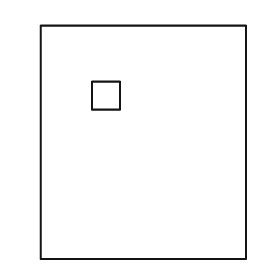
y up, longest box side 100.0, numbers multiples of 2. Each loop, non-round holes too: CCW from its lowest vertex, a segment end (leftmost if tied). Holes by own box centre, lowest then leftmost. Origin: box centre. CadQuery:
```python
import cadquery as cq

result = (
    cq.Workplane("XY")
    .moveTo(-44.0, -50.0)
    .lineTo(44.0, -50.0)
    .lineTo(44.0, 50.0)
    .lineTo(-44.0, 50.0)
    .close()
    .moveTo(-22.0, 14.0)
    .lineTo(-10.0, 14.0)
    .lineTo(-10.0, 26.0)
    .lineTo(-22.0, 26.0)
    .close()
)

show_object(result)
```